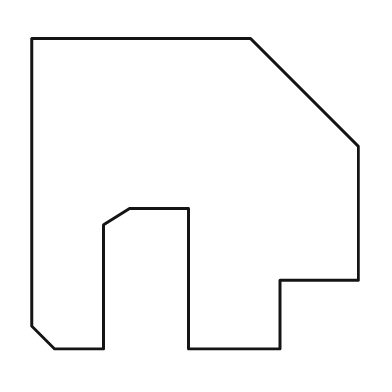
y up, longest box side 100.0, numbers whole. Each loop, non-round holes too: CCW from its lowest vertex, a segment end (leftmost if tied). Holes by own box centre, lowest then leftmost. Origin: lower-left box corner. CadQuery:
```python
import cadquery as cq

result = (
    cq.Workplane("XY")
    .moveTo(7.0, 0.0)
    .lineTo(22.0, 0.0)
    .lineTo(22.0, 38.0)
    .lineTo(30.0, 43.0)
    .lineTo(48.0, 43.0)
    .lineTo(48.0, 0.0)
    .lineTo(76.0, 0.0)
    .lineTo(76.0, 21.0)
    .lineTo(100.0, 21.0)
    .lineTo(100.0, 62.0)
    .lineTo(67.0, 95.0)
    .lineTo(0.0, 95.0)
    .lineTo(0.0, 7.0)
    .close()
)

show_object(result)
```